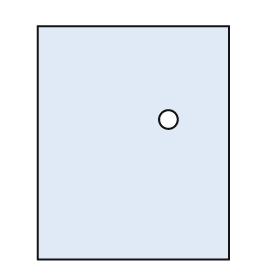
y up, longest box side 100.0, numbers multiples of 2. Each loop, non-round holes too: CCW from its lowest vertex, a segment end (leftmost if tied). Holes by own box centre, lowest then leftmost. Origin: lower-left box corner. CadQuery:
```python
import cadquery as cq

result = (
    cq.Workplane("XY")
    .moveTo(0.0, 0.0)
    .lineTo(82.0, 0.0)
    .lineTo(82.0, 100.0)
    .lineTo(0.0, 100.0)
    .close()
    .moveTo(56.0, 60.0)
    .circle(4.0)
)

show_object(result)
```